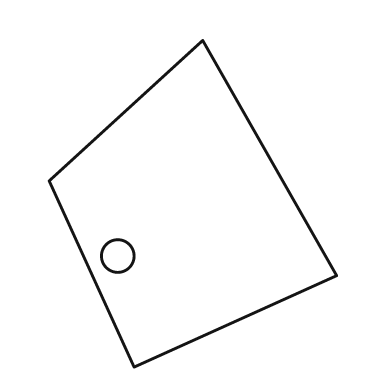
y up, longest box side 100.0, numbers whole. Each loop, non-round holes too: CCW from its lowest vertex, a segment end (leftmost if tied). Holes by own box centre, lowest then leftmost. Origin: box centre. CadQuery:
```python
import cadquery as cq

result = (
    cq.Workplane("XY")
    .moveTo(-18.0, -50.0)
    .lineTo(44.0, -22.0)
    .lineTo(3.0, 50.0)
    .lineTo(-44.0, 7.0)
    .close()
    .moveTo(-23.0, -16.0)
    .circle(5.0)
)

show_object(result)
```